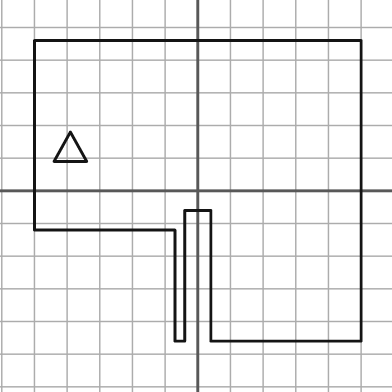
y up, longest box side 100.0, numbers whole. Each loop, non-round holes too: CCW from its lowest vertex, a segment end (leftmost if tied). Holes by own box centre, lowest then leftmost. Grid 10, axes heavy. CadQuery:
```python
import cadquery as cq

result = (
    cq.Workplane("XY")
    .moveTo(-7.0, -46.0)
    .lineTo(-4.0, -46.0)
    .lineTo(-4.0, -6.0)
    .lineTo(4.0, -6.0)
    .lineTo(4.0, -46.0)
    .lineTo(50.0, -46.0)
    .lineTo(50.0, 46.0)
    .lineTo(-50.0, 46.0)
    .lineTo(-50.0, -12.0)
    .lineTo(-7.0, -12.0)
    .close()
    .moveTo(-44.0, 9.0)
    .lineTo(-34.0, 9.0)
    .lineTo(-39.0, 18.0)
    .close()
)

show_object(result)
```